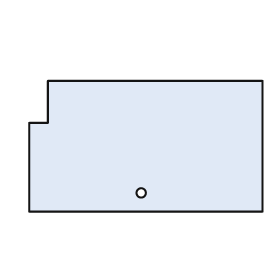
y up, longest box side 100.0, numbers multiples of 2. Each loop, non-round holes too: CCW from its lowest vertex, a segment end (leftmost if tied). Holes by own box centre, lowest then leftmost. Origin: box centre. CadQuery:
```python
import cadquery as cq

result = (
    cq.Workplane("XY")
    .moveTo(-50.0, -28.0)
    .lineTo(50.0, -28.0)
    .lineTo(50.0, 28.0)
    .lineTo(-42.0, 28.0)
    .lineTo(-42.0, 10.0)
    .lineTo(-50.0, 10.0)
    .close()
    .moveTo(-2.0, -20.0)
    .circle(2.0)
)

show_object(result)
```